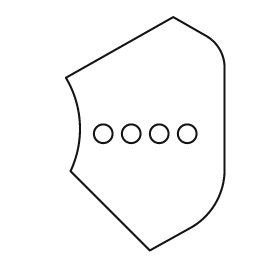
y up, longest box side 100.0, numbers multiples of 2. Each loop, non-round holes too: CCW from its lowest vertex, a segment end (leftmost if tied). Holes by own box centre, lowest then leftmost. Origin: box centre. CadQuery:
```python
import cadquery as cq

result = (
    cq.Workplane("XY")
    .moveTo(2.0, -50.0)
    .lineTo(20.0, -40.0)
    .threePointArc((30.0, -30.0), (34.0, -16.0))
    .lineTo(34.0, 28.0)
    .threePointArc((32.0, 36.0), (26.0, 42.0))
    .lineTo(12.0, 50.0)
    .lineTo(-34.0, 24.0)
    .threePointArc((-28.0, 4.0), (-32.0, -16.0))
    .close()
    .moveTo(-18.0, 0.0)
    .circle(4.0)
    .moveTo(-6.0, 0.0)
    .circle(4.0)
    .moveTo(6.0, 0.0)
    .circle(4.0)
    .moveTo(18.0, 0.0)
    .circle(4.0)
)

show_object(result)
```